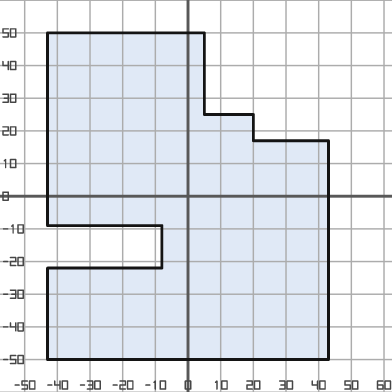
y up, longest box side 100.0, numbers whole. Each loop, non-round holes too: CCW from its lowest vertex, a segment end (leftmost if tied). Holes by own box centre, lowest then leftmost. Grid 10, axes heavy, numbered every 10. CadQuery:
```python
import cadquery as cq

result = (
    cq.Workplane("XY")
    .moveTo(-43.0, -50.0)
    .lineTo(43.0, -50.0)
    .lineTo(43.0, 17.0)
    .lineTo(20.0, 17.0)
    .lineTo(20.0, 25.0)
    .lineTo(5.0, 25.0)
    .lineTo(5.0, 50.0)
    .lineTo(-43.0, 50.0)
    .lineTo(-43.0, -9.0)
    .lineTo(-8.0, -9.0)
    .lineTo(-8.0, -22.0)
    .lineTo(-43.0, -22.0)
    .close()
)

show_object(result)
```